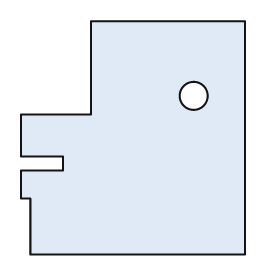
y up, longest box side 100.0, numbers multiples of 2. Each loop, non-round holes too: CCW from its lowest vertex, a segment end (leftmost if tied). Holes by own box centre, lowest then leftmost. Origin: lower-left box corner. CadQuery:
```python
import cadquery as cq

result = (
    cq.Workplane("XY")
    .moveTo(4.0, 0.0)
    .lineTo(96.0, 0.0)
    .lineTo(96.0, 100.0)
    .lineTo(30.0, 100.0)
    .lineTo(30.0, 60.0)
    .lineTo(0.0, 60.0)
    .lineTo(0.0, 42.0)
    .lineTo(18.0, 42.0)
    .lineTo(18.0, 36.0)
    .lineTo(0.0, 36.0)
    .lineTo(0.0, 24.0)
    .lineTo(4.0, 24.0)
    .close()
    .moveTo(74.0, 68.0)
    .circle(6.0)
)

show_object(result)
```